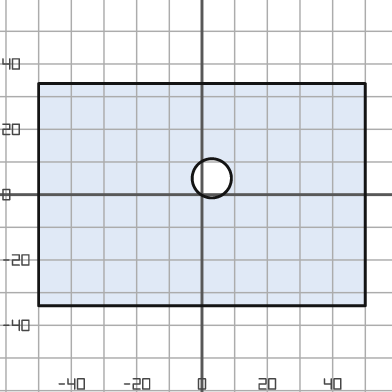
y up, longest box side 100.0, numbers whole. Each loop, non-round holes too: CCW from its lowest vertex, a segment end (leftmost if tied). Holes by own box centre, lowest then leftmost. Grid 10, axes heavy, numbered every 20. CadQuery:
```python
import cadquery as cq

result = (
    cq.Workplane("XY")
    .moveTo(-50.0, -34.0)
    .lineTo(50.0, -34.0)
    .lineTo(50.0, 34.0)
    .lineTo(-50.0, 34.0)
    .close()
    .moveTo(3.0, 5.0)
    .circle(6.0)
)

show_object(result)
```